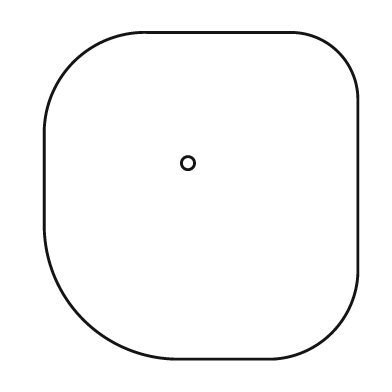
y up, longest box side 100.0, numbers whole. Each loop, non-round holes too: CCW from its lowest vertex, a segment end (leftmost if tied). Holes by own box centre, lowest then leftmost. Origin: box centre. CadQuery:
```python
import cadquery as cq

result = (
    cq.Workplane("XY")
    .moveTo(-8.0, -50.0)
    .lineTo(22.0, -50.0)
    .threePointArc((40.0, -42.0), (48.0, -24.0))
    .lineTo(48.0, 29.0)
    .threePointArc((42.0, 44.0), (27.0, 50.0))
    .lineTo(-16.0, 50.0)
    .threePointArc((-39.0, 41.0), (-48.0, 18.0))
    .lineTo(-48.0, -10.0)
    .threePointArc((-36.0, -38.0), (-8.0, -50.0))
    .close()
    .moveTo(-4.0, 10.0)
    .circle(2.0)
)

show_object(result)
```